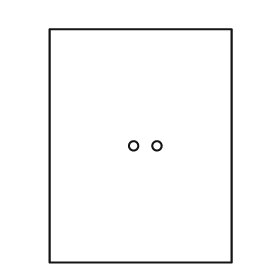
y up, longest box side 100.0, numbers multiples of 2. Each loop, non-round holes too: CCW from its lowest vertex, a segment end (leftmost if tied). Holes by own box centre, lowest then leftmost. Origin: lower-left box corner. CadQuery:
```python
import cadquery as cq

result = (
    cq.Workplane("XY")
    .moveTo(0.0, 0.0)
    .lineTo(78.0, 0.0)
    .lineTo(78.0, 100.0)
    .lineTo(0.0, 100.0)
    .close()
    .moveTo(36.0, 50.0)
    .circle(2.0)
    .moveTo(46.0, 50.0)
    .circle(2.0)
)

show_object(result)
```